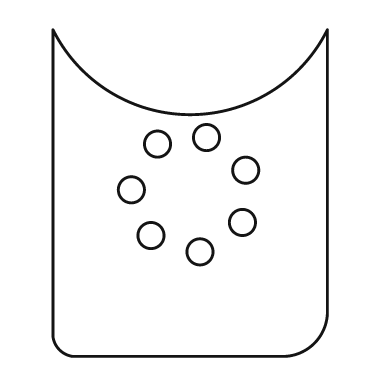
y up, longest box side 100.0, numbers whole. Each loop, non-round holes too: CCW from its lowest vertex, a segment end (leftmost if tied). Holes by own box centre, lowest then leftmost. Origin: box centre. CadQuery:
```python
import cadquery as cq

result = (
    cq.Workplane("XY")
    .moveTo(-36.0, -50.0)
    .lineTo(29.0, -50.0)
    .threePointArc((38.0, -46.0), (42.0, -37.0))
    .lineTo(42.0, 50.0)
    .threePointArc((0.0, 24.0), (-42.0, 50.0))
    .lineTo(-42.0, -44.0)
    .threePointArc((-40.0, -48.0), (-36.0, -50.0))
    .close()
    .moveTo(3.0, -18.0)
    .circle(4.0)
    .moveTo(-12.0, -13.0)
    .circle(4.0)
    .moveTo(16.0, -9.0)
    .circle(4.0)
    .moveTo(-18.0, 1.0)
    .circle(4.0)
    .moveTo(17.0, 7.0)
    .circle(4.0)
    .moveTo(-10.0, 15.0)
    .circle(4.0)
    .moveTo(5.0, 17.0)
    .circle(4.0)
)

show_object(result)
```